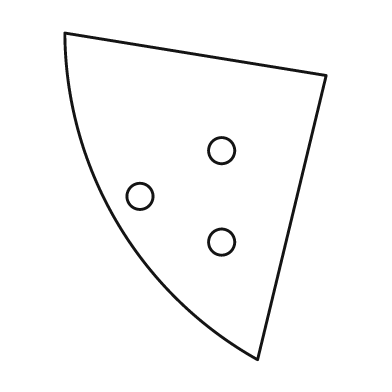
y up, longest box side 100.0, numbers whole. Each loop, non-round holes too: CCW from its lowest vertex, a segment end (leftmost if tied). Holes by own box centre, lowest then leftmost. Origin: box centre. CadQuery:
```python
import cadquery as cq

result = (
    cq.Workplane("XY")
    .moveTo(19.0, -50.0)
    .lineTo(40.0, 37.0)
    .lineTo(-40.0, 50.0)
    .threePointArc((-24.0, -8.0), (19.0, -50.0))
    .close()
    .moveTo(8.0, -14.0)
    .circle(4.0)
    .moveTo(-17.0, 0.0)
    .circle(4.0)
    .moveTo(8.0, 14.0)
    .circle(4.0)
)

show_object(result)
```